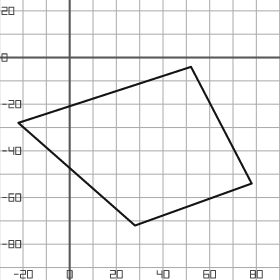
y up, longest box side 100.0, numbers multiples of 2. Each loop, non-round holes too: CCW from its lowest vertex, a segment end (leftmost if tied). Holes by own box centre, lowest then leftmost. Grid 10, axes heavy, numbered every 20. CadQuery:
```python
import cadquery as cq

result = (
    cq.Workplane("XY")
    .moveTo(28.0, -72.0)
    .lineTo(78.0, -54.0)
    .lineTo(52.0, -4.0)
    .lineTo(-22.0, -28.0)
    .close()
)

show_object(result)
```